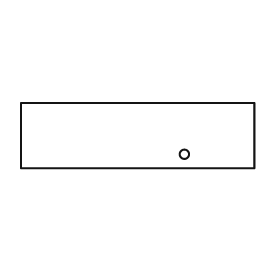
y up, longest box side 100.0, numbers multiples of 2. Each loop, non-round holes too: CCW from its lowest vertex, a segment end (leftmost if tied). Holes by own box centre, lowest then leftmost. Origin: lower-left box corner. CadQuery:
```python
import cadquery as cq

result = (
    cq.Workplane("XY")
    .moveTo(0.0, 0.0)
    .lineTo(100.0, 0.0)
    .lineTo(100.0, 28.0)
    .lineTo(0.0, 28.0)
    .close()
    .moveTo(70.0, 6.0)
    .circle(2.0)
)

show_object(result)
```